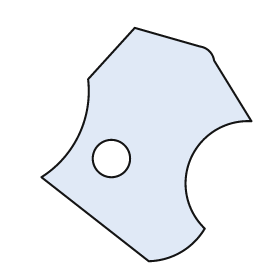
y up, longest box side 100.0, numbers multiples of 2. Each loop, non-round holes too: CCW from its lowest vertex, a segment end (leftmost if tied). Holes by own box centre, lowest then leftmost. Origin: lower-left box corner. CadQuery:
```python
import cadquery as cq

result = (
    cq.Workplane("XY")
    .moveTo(46.0, 0.0)
    .threePointArc((60.0, 4.0), (70.0, 14.0))
    .threePointArc((64.0, 44.0), (90.0, 60.0))
    .lineTo(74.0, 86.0)
    .threePointArc((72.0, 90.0), (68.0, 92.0))
    .lineTo(40.0, 100.0)
    .lineTo(20.0, 78.0)
    .threePointArc((16.0, 54.0), (0.0, 36.0))
    .close()
    .moveTo(30.0, 44.0)
    .circle(8.0)
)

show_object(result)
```